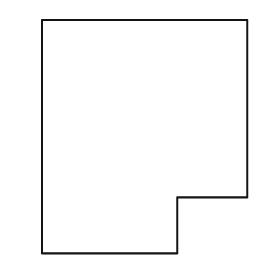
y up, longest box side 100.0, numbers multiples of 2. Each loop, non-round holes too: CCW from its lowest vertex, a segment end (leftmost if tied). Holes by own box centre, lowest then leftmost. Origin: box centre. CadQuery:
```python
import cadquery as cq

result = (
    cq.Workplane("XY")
    .moveTo(-44.0, -50.0)
    .lineTo(14.0, -50.0)
    .lineTo(14.0, -26.0)
    .lineTo(44.0, -26.0)
    .lineTo(44.0, 50.0)
    .lineTo(-44.0, 50.0)
    .close()
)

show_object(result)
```